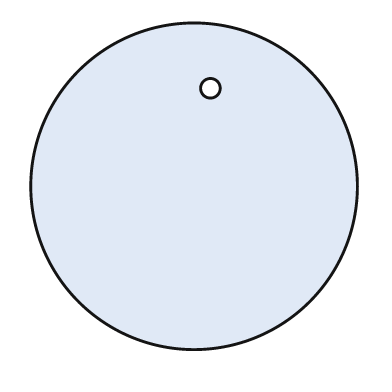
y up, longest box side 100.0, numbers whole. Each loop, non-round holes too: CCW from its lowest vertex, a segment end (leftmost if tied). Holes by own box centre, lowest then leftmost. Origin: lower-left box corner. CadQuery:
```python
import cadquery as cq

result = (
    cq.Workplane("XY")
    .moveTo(50.0, 50.0)
    .circle(50.0)
    .moveTo(55.0, 80.0)
    .circle(3.0)
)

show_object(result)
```